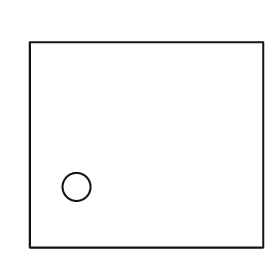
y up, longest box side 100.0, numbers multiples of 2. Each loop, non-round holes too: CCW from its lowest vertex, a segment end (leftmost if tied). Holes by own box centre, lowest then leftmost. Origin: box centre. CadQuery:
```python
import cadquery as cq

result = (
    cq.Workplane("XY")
    .moveTo(-50.0, -44.0)
    .lineTo(50.0, -44.0)
    .lineTo(50.0, 44.0)
    .lineTo(-50.0, 44.0)
    .close()
    .moveTo(-30.0, -18.0)
    .circle(6.0)
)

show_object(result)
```